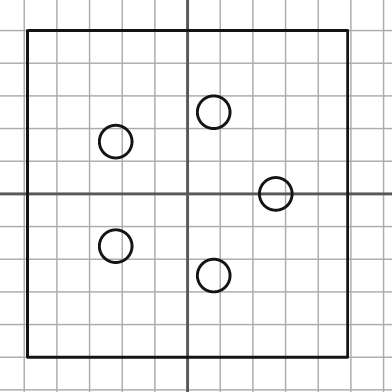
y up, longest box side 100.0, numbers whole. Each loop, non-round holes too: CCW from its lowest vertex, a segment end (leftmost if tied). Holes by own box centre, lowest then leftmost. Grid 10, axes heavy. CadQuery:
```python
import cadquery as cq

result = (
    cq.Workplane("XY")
    .moveTo(-49.0, -50.0)
    .lineTo(49.0, -50.0)
    .lineTo(49.0, 50.0)
    .lineTo(-49.0, 50.0)
    .close()
    .moveTo(8.0, -25.0)
    .circle(5.0)
    .moveTo(-22.0, -16.0)
    .circle(5.0)
    .moveTo(27.0, 0.0)
    .circle(5.0)
    .moveTo(-22.0, 16.0)
    .circle(5.0)
    .moveTo(8.0, 25.0)
    .circle(5.0)
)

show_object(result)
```